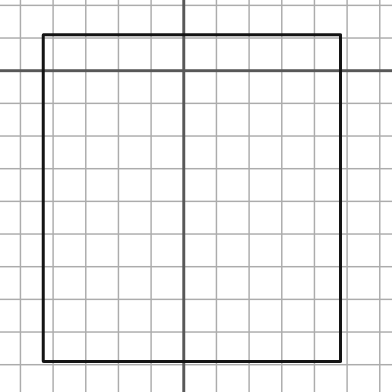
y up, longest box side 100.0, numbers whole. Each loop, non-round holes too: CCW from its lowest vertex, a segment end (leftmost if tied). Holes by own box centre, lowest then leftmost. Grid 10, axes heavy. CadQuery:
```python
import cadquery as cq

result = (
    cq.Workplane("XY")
    .moveTo(-43.0, -89.0)
    .lineTo(48.0, -89.0)
    .lineTo(48.0, 11.0)
    .lineTo(-43.0, 11.0)
    .close()
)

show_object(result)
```